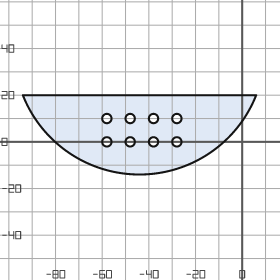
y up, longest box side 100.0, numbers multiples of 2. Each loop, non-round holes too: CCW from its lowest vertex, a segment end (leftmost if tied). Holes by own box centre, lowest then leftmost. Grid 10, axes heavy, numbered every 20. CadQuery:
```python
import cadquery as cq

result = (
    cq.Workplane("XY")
    .moveTo(-94.0, 20.0)
    .threePointArc((-44.0, -14.0), (6.0, 20.0))
    .close()
    .moveTo(-58.0, 0.0)
    .circle(2.0)
    .moveTo(-48.0, 0.0)
    .circle(2.0)
    .moveTo(-38.0, 0.0)
    .circle(2.0)
    .moveTo(-28.0, 0.0)
    .circle(2.0)
    .moveTo(-58.0, 10.0)
    .circle(2.0)
    .moveTo(-48.0, 10.0)
    .circle(2.0)
    .moveTo(-38.0, 10.0)
    .circle(2.0)
    .moveTo(-28.0, 10.0)
    .circle(2.0)
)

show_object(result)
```